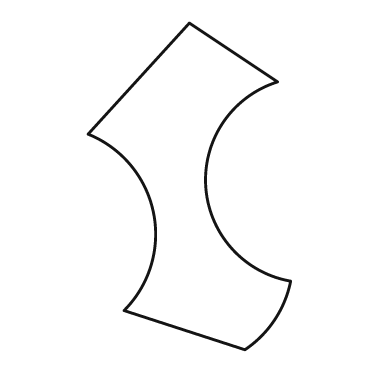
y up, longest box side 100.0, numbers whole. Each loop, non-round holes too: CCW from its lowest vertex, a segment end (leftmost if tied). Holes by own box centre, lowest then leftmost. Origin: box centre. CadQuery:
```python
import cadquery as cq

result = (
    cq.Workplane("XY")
    .moveTo(17.0, -50.0)
    .threePointArc((26.0, -41.0), (31.0, -29.0))
    .threePointArc((5.0, 0.0), (27.0, 32.0))
    .lineTo(0.0, 50.0)
    .lineTo(-31.0, 16.0)
    .threePointArc((-11.0, -8.0), (-20.0, -38.0))
    .close()
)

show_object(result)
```